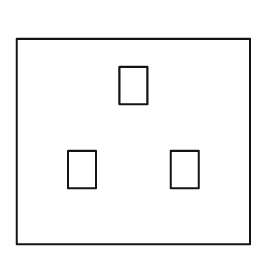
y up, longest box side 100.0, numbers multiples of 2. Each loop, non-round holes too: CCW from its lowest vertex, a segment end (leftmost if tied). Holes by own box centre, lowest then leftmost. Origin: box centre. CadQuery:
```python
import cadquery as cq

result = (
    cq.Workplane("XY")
    .moveTo(-50.0, -44.0)
    .lineTo(50.0, -44.0)
    .lineTo(50.0, 44.0)
    .lineTo(-50.0, 44.0)
    .close()
    .moveTo(-28.0, -20.0)
    .lineTo(-16.0, -20.0)
    .lineTo(-16.0, -4.0)
    .lineTo(-28.0, -4.0)
    .close()
    .moveTo(16.0, -20.0)
    .lineTo(28.0, -20.0)
    .lineTo(28.0, -4.0)
    .lineTo(16.0, -4.0)
    .close()
    .moveTo(-6.0, 16.0)
    .lineTo(6.0, 16.0)
    .lineTo(6.0, 32.0)
    .lineTo(-6.0, 32.0)
    .close()
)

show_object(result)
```